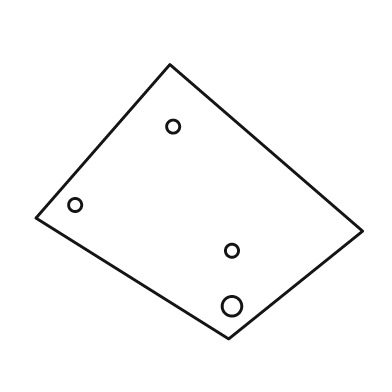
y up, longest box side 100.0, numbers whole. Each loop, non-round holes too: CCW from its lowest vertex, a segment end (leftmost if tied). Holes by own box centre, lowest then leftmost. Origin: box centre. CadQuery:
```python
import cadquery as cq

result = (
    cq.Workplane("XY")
    .moveTo(9.0, -42.0)
    .lineTo(50.0, -9.0)
    .lineTo(-9.0, 42.0)
    .lineTo(-50.0, -5.0)
    .close()
    .moveTo(10.0, -32.0)
    .circle(3.0)
    .moveTo(10.0, -15.0)
    .circle(2.0)
    .moveTo(-38.0, -1.0)
    .circle(2.0)
    .moveTo(-8.0, 23.0)
    .circle(2.0)
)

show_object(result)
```